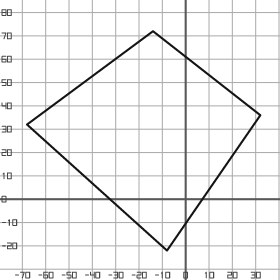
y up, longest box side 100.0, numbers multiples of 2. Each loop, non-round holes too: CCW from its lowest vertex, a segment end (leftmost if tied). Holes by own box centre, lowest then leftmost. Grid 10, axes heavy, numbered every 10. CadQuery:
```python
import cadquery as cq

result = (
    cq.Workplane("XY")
    .moveTo(-8.0, -22.0)
    .lineTo(32.0, 36.0)
    .lineTo(-14.0, 72.0)
    .lineTo(-68.0, 32.0)
    .close()
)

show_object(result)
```